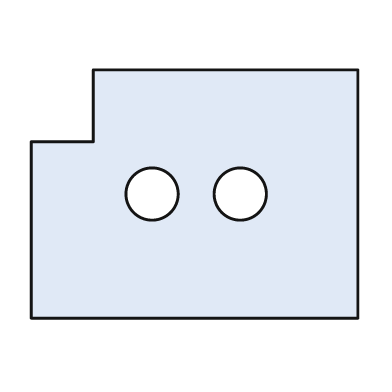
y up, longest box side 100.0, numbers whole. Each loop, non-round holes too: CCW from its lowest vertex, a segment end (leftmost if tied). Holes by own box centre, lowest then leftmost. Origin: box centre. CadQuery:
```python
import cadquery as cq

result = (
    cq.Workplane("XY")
    .moveTo(-50.0, -38.0)
    .lineTo(50.0, -38.0)
    .lineTo(50.0, 38.0)
    .lineTo(-31.0, 38.0)
    .lineTo(-31.0, 16.0)
    .lineTo(-50.0, 16.0)
    .close()
    .moveTo(-13.0, 0.0)
    .circle(8.0)
    .moveTo(14.0, 0.0)
    .circle(8.0)
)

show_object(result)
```